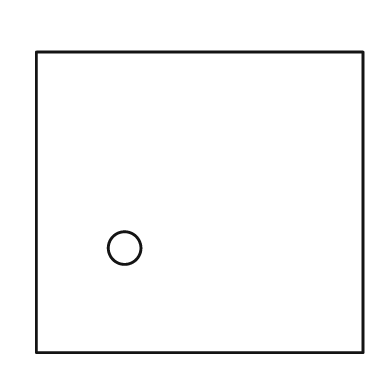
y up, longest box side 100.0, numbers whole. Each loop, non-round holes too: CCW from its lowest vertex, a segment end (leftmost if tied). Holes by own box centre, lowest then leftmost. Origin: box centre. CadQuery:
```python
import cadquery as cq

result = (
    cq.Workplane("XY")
    .moveTo(-50.0, -46.0)
    .lineTo(50.0, -46.0)
    .lineTo(50.0, 46.0)
    .lineTo(-50.0, 46.0)
    .close()
    .moveTo(-23.0, -14.0)
    .circle(5.0)
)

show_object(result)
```